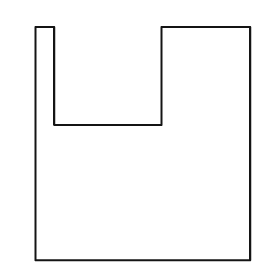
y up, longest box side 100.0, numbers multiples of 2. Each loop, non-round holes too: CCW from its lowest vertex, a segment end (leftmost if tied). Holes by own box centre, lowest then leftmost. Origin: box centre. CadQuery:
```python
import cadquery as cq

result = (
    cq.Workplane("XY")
    .moveTo(-46.0, -50.0)
    .lineTo(46.0, -50.0)
    .lineTo(46.0, 50.0)
    .lineTo(8.0, 50.0)
    .lineTo(8.0, 8.0)
    .lineTo(-38.0, 8.0)
    .lineTo(-38.0, 50.0)
    .lineTo(-46.0, 50.0)
    .close()
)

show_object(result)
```